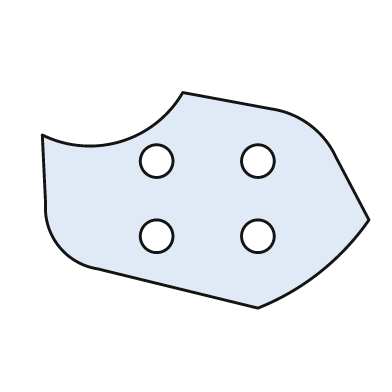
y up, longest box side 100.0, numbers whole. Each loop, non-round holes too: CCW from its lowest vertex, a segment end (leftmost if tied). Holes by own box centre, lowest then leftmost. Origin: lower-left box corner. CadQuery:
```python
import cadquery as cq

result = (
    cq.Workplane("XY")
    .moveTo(66.0, 0.0)
    .threePointArc((85.0, 11.0), (100.0, 27.0))
    .lineTo(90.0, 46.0)
    .threePointArc((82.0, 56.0), (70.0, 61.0))
    .lineTo(43.0, 66.0)
    .threePointArc((24.0, 51.0), (0.0, 53.0))
    .lineTo(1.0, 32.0)
    .threePointArc((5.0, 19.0), (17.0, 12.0))
    .close()
    .moveTo(35.0, 22.0)
    .circle(5.0)
    .moveTo(66.0, 22.0)
    .circle(5.0)
    .moveTo(35.0, 45.0)
    .circle(5.0)
    .moveTo(66.0, 45.0)
    .circle(5.0)
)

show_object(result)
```